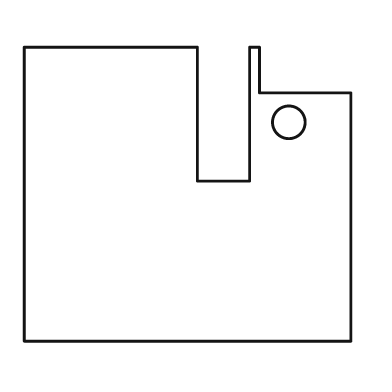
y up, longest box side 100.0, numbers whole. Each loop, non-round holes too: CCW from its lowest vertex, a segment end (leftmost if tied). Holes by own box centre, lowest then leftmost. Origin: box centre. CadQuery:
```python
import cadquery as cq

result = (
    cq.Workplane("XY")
    .moveTo(-50.0, -45.0)
    .lineTo(50.0, -45.0)
    .lineTo(50.0, 31.0)
    .lineTo(22.0, 31.0)
    .lineTo(22.0, 45.0)
    .lineTo(19.0, 45.0)
    .lineTo(19.0, 4.0)
    .lineTo(3.0, 4.0)
    .lineTo(3.0, 45.0)
    .lineTo(-50.0, 45.0)
    .close()
    .moveTo(31.0, 22.0)
    .circle(5.0)
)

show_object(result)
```